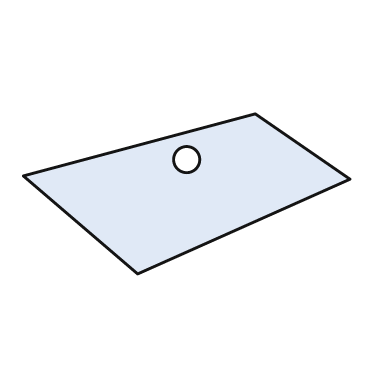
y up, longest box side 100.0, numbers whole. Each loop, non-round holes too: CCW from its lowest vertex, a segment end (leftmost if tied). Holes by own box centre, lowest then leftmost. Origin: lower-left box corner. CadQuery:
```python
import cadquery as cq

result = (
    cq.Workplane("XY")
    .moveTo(35.0, 0.0)
    .lineTo(100.0, 29.0)
    .lineTo(71.0, 49.0)
    .lineTo(0.0, 30.0)
    .close()
    .moveTo(50.0, 35.0)
    .circle(4.0)
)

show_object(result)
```